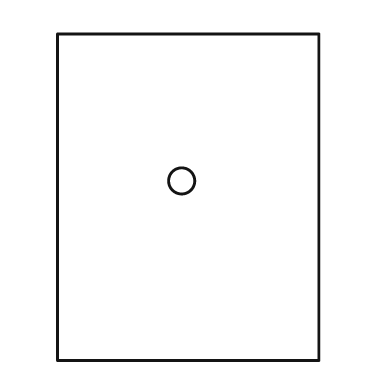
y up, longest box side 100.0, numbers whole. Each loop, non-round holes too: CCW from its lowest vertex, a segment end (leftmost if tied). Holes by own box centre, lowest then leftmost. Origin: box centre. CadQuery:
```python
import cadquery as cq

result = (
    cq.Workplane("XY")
    .moveTo(-40.0, -50.0)
    .lineTo(40.0, -50.0)
    .lineTo(40.0, 50.0)
    .lineTo(-40.0, 50.0)
    .close()
    .moveTo(-2.0, 5.0)
    .circle(4.0)
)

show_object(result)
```